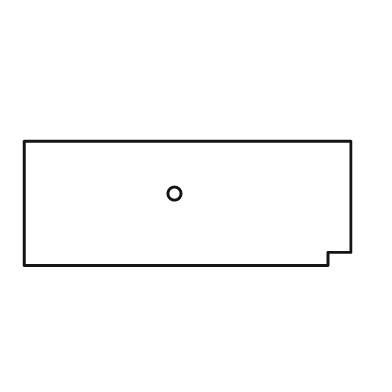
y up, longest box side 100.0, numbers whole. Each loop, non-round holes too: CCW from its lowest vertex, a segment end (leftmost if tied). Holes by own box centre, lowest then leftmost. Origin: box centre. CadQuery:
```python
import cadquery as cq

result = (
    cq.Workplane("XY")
    .moveTo(-50.0, -19.0)
    .lineTo(43.0, -19.0)
    .lineTo(43.0, -15.0)
    .lineTo(50.0, -15.0)
    .lineTo(50.0, 19.0)
    .lineTo(-50.0, 19.0)
    .close()
    .moveTo(-4.0, 3.0)
    .circle(2.0)
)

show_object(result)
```